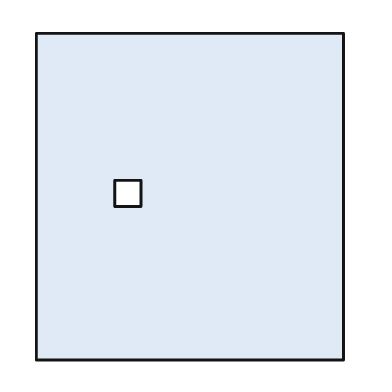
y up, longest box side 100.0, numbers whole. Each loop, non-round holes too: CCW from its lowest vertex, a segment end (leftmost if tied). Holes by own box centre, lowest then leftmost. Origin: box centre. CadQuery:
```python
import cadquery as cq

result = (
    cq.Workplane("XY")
    .moveTo(-47.0, -50.0)
    .lineTo(47.0, -50.0)
    .lineTo(47.0, 50.0)
    .lineTo(-47.0, 50.0)
    .close()
    .moveTo(-23.0, -3.0)
    .lineTo(-15.0, -3.0)
    .lineTo(-15.0, 5.0)
    .lineTo(-23.0, 5.0)
    .close()
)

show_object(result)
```